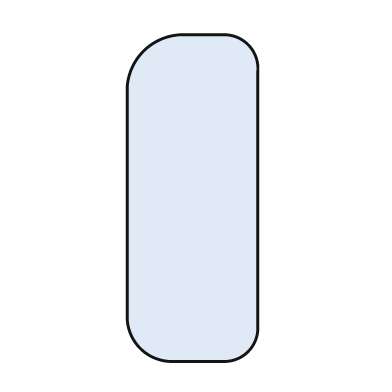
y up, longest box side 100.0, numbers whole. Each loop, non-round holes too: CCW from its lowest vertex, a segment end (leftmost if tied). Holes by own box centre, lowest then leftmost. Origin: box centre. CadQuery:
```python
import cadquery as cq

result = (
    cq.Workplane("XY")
    .moveTo(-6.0, -50.0)
    .lineTo(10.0, -50.0)
    .threePointArc((17.0, -47.0), (20.0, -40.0))
    .lineTo(20.0, 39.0)
    .threePointArc((17.0, 47.0), (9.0, 50.0))
    .lineTo(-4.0, 50.0)
    .threePointArc((-15.0, 45.0), (-20.0, 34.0))
    .lineTo(-20.0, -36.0)
    .threePointArc((-16.0, -46.0), (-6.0, -50.0))
    .close()
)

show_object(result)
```